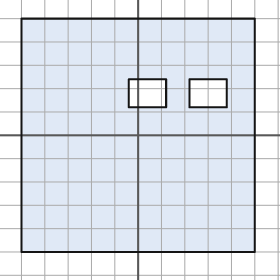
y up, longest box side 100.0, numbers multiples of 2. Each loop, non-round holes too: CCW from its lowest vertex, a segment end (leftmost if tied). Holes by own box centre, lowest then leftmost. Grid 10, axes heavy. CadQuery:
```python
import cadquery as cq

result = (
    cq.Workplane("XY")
    .moveTo(-50.0, -50.0)
    .lineTo(50.0, -50.0)
    .lineTo(50.0, 50.0)
    .lineTo(-50.0, 50.0)
    .close()
    .moveTo(-4.0, 12.0)
    .lineTo(12.0, 12.0)
    .lineTo(12.0, 24.0)
    .lineTo(-4.0, 24.0)
    .close()
    .moveTo(22.0, 12.0)
    .lineTo(38.0, 12.0)
    .lineTo(38.0, 24.0)
    .lineTo(22.0, 24.0)
    .close()
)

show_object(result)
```